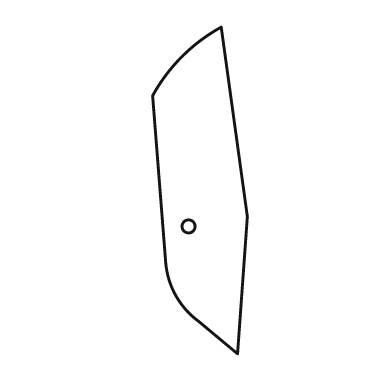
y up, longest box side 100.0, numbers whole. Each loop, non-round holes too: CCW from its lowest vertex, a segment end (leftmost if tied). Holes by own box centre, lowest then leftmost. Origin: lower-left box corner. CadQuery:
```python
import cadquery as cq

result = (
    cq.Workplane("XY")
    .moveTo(26.0, 0.0)
    .lineTo(29.0, 42.0)
    .lineTo(21.0, 100.0)
    .threePointArc((9.0, 91.0), (0.0, 79.0))
    .lineTo(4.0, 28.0)
    .threePointArc((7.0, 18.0), (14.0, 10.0))
    .close()
    .moveTo(11.0, 39.0)
    .circle(2.0)
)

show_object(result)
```